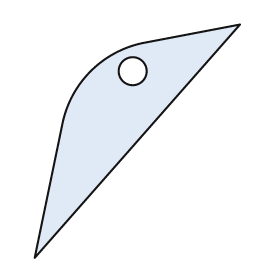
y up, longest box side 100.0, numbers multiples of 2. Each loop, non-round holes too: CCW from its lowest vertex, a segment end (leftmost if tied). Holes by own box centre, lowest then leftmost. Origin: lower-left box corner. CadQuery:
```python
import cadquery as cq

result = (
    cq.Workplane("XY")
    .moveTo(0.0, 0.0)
    .lineTo(88.0, 100.0)
    .lineTo(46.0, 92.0)
    .threePointArc((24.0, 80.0), (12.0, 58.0))
    .close()
    .moveTo(42.0, 80.0)
    .circle(6.0)
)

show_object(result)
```